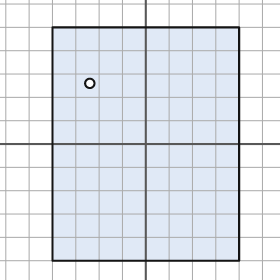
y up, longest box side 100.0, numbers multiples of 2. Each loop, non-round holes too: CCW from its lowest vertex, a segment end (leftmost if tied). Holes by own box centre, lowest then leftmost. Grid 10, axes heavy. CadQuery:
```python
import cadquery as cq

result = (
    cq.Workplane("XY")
    .moveTo(-40.0, -50.0)
    .lineTo(40.0, -50.0)
    .lineTo(40.0, 50.0)
    .lineTo(-40.0, 50.0)
    .close()
    .moveTo(-24.0, 26.0)
    .circle(2.0)
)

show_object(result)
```